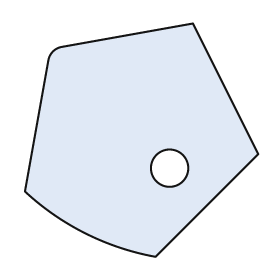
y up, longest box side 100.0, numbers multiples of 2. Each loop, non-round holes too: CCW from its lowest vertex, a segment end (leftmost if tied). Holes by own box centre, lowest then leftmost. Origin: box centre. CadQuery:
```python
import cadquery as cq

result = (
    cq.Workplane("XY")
    .moveTo(6.0, -50.0)
    .lineTo(50.0, -6.0)
    .lineTo(22.0, 50.0)
    .lineTo(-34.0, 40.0)
    .threePointArc((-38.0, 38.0), (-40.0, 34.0))
    .lineTo(-50.0, -22.0)
    .threePointArc((-24.0, -40.0), (6.0, -50.0))
    .close()
    .moveTo(12.0, -12.0)
    .circle(8.0)
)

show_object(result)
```